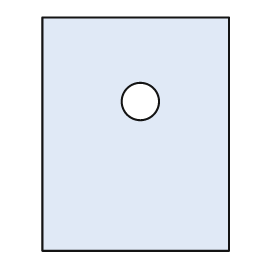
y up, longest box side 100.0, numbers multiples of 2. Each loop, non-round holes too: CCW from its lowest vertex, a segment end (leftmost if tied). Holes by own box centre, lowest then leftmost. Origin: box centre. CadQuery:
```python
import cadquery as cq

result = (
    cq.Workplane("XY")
    .moveTo(-40.0, -50.0)
    .lineTo(40.0, -50.0)
    .lineTo(40.0, 50.0)
    .lineTo(-40.0, 50.0)
    .close()
    .moveTo(2.0, 14.0)
    .circle(8.0)
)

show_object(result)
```